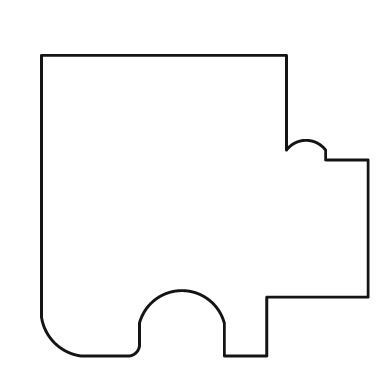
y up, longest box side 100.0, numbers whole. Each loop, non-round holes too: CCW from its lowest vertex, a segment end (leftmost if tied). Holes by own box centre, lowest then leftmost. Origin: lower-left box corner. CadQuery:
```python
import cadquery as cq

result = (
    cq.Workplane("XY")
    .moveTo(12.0, 0.0)
    .lineTo(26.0, 0.0)
    .threePointArc((29.0, 1.0), (30.0, 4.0))
    .lineTo(30.0, 10.0)
    .threePointArc((43.0, 20.0), (56.0, 10.0))
    .lineTo(56.0, 0.0)
    .lineTo(69.0, 0.0)
    .lineTo(69.0, 18.0)
    .lineTo(100.0, 18.0)
    .lineTo(100.0, 60.0)
    .lineTo(87.0, 60.0)
    .lineTo(87.0, 63.0)
    .threePointArc((81.0, 66.0), (75.0, 63.0))
    .lineTo(75.0, 92.0)
    .lineTo(0.0, 92.0)
    .lineTo(0.0, 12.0)
    .threePointArc((4.0, 4.0), (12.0, 0.0))
    .close()
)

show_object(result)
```